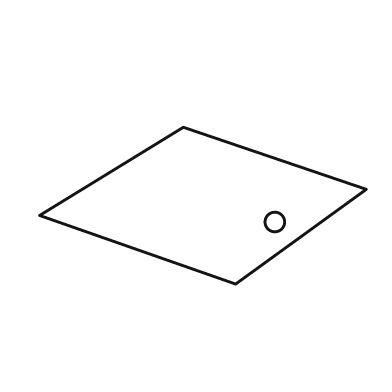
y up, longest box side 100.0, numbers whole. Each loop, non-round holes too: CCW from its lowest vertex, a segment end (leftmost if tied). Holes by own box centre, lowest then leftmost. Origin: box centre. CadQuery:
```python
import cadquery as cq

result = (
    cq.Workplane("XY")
    .moveTo(10.0, -24.0)
    .lineTo(50.0, 5.0)
    .lineTo(-6.0, 24.0)
    .lineTo(-50.0, -3.0)
    .close()
    .moveTo(22.0, -5.0)
    .circle(3.0)
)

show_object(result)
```